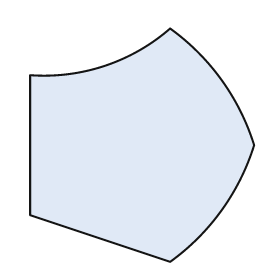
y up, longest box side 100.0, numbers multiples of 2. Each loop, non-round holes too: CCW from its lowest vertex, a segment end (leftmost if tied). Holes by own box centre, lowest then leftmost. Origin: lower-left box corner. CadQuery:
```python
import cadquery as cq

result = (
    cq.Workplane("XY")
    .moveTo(60.0, 0.0)
    .threePointArc((82.0, 22.0), (96.0, 50.0))
    .threePointArc((82.0, 78.0), (60.0, 100.0))
    .threePointArc((32.0, 84.0), (0.0, 80.0))
    .lineTo(0.0, 20.0)
    .close()
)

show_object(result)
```